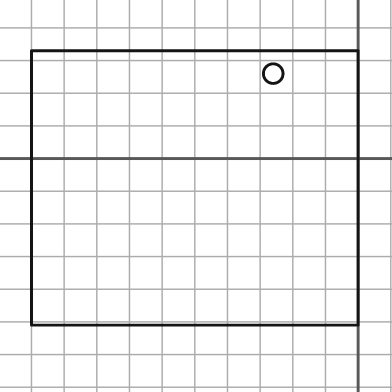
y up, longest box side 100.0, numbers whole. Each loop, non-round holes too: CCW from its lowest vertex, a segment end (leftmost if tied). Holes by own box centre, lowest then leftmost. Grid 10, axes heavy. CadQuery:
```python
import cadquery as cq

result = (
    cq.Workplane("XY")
    .moveTo(-100.0, -51.0)
    .lineTo(0.0, -51.0)
    .lineTo(0.0, 33.0)
    .lineTo(-100.0, 33.0)
    .close()
    .moveTo(-26.0, 26.0)
    .circle(3.0)
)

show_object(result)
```